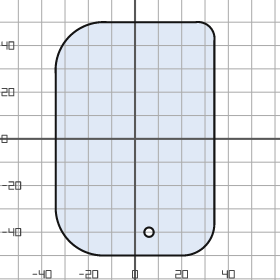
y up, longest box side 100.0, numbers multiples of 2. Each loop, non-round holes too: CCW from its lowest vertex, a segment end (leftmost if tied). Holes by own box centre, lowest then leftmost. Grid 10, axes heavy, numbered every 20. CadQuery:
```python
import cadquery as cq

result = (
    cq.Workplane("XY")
    .moveTo(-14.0, -50.0)
    .lineTo(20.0, -50.0)
    .threePointArc((30.0, -46.0), (34.0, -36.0))
    .lineTo(34.0, 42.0)
    .threePointArc((32.0, 48.0), (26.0, 50.0))
    .lineTo(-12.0, 50.0)
    .threePointArc((-28.0, 44.0), (-34.0, 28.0))
    .lineTo(-34.0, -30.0)
    .threePointArc((-28.0, -44.0), (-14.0, -50.0))
    .close()
    .moveTo(6.0, -40.0)
    .circle(2.0)
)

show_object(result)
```